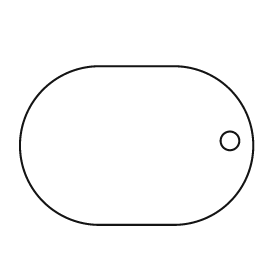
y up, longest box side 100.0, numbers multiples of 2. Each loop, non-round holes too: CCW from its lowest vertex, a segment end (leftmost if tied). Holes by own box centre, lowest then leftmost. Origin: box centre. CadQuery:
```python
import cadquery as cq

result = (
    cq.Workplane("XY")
    .moveTo(-16.0, -34.0)
    .lineTo(16.0, -34.0)
    .threePointArc((50.0, 0.0), (16.0, 34.0))
    .lineTo(-16.0, 34.0)
    .threePointArc((-50.0, 0.0), (-16.0, -34.0))
    .close()
    .moveTo(40.0, 2.0)
    .circle(4.0)
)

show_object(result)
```